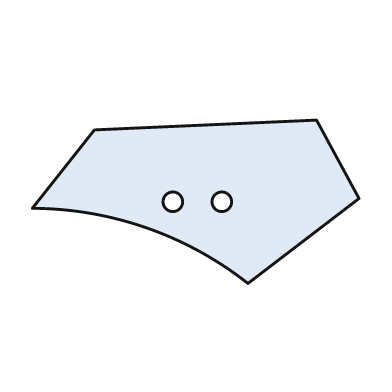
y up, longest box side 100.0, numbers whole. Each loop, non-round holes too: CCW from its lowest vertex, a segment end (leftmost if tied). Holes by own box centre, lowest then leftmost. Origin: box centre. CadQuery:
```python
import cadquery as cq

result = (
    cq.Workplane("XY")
    .moveTo(16.0, -25.0)
    .lineTo(50.0, 1.0)
    .lineTo(37.0, 25.0)
    .lineTo(-31.0, 22.0)
    .lineTo(-50.0, -2.0)
    .threePointArc((-15.0, -8.0), (16.0, -25.0))
    .close()
    .moveTo(-7.0, 0.0)
    .circle(3.0)
    .moveTo(8.0, 0.0)
    .circle(3.0)
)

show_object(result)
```